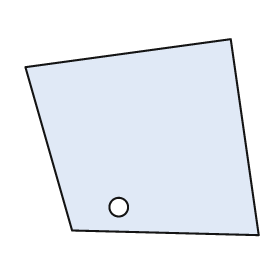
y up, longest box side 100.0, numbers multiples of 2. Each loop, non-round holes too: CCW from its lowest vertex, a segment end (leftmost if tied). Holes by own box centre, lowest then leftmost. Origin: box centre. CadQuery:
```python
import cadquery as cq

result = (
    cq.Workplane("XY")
    .moveTo(50.0, -42.0)
    .lineTo(38.0, 42.0)
    .lineTo(-50.0, 30.0)
    .lineTo(-30.0, -40.0)
    .close()
    .moveTo(-10.0, -30.0)
    .circle(4.0)
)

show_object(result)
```